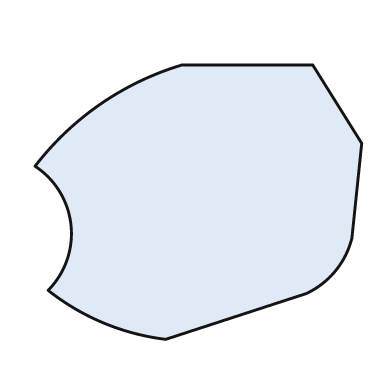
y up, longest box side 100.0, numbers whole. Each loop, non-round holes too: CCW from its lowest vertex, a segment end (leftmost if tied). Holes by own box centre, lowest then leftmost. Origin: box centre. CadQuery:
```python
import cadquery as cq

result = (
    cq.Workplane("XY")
    .moveTo(-10.0, -42.0)
    .lineTo(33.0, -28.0)
    .threePointArc((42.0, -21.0), (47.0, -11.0))
    .lineTo(50.0, 18.0)
    .lineTo(35.0, 42.0)
    .lineTo(-5.0, 42.0)
    .threePointArc((-30.0, 30.0), (-50.0, 11.0))
    .threePointArc((-39.0, -7.0), (-46.0, -27.0))
    .threePointArc((-29.0, -37.0), (-10.0, -42.0))
    .close()
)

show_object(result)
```